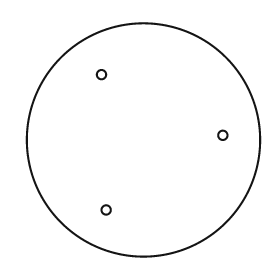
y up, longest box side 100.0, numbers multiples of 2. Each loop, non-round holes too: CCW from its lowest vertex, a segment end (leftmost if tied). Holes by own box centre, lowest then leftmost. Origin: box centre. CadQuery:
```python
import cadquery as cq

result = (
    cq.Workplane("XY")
    .moveTo(0.0, 0.0)
    .circle(50.0)
    .moveTo(-16.0, -30.0)
    .circle(2.0)
    .moveTo(34.0, 2.0)
    .circle(2.0)
    .moveTo(-18.0, 28.0)
    .circle(2.0)
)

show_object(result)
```